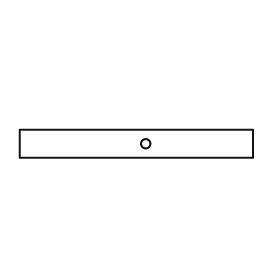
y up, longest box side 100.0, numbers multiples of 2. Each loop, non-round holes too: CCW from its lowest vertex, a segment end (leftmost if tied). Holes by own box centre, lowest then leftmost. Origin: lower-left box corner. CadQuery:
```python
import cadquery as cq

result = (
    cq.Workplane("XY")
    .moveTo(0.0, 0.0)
    .lineTo(100.0, 0.0)
    .lineTo(100.0, 12.0)
    .lineTo(0.0, 12.0)
    .close()
    .moveTo(54.0, 6.0)
    .circle(2.0)
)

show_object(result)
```